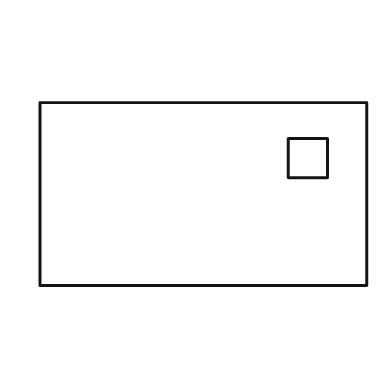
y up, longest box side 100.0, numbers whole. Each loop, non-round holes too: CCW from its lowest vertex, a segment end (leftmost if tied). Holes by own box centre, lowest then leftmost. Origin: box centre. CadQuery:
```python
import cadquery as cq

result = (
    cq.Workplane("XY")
    .moveTo(-50.0, -28.0)
    .lineTo(50.0, -28.0)
    .lineTo(50.0, 28.0)
    .lineTo(-50.0, 28.0)
    .close()
    .moveTo(26.0, 5.0)
    .lineTo(38.0, 5.0)
    .lineTo(38.0, 17.0)
    .lineTo(26.0, 17.0)
    .close()
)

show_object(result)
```